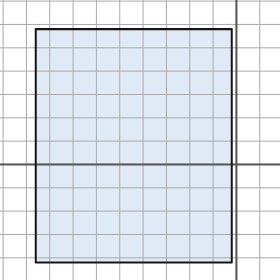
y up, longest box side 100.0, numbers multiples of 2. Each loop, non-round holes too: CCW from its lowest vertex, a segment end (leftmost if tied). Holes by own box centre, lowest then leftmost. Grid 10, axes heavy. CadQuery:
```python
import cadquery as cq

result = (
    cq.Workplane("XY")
    .moveTo(-86.0, -42.0)
    .lineTo(-2.0, -42.0)
    .lineTo(-2.0, 58.0)
    .lineTo(-86.0, 58.0)
    .close()
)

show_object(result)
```